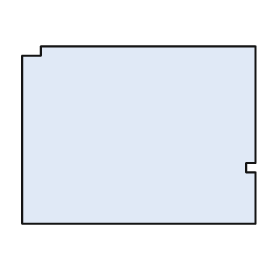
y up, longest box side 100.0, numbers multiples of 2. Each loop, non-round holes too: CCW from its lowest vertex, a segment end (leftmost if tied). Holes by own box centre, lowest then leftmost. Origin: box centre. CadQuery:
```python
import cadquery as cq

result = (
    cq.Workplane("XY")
    .moveTo(-50.0, -38.0)
    .lineTo(50.0, -38.0)
    .lineTo(50.0, -16.0)
    .lineTo(46.0, -16.0)
    .lineTo(46.0, -12.0)
    .lineTo(50.0, -12.0)
    .lineTo(50.0, 38.0)
    .lineTo(-42.0, 38.0)
    .lineTo(-42.0, 34.0)
    .lineTo(-50.0, 34.0)
    .close()
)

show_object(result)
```